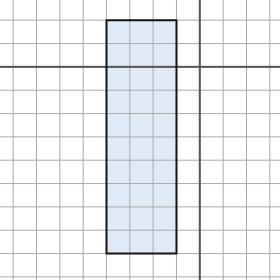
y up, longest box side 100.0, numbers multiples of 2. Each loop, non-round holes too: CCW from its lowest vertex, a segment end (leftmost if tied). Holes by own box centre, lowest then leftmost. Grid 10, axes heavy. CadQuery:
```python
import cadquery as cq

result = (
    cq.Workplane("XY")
    .moveTo(-40.0, -80.0)
    .lineTo(-10.0, -80.0)
    .lineTo(-10.0, 20.0)
    .lineTo(-40.0, 20.0)
    .close()
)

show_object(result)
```